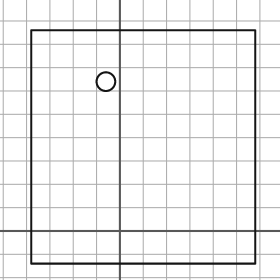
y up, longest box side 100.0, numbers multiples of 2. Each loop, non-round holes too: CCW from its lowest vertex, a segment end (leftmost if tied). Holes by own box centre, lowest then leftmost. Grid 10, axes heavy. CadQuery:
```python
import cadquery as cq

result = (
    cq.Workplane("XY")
    .moveTo(-38.0, -14.0)
    .lineTo(58.0, -14.0)
    .lineTo(58.0, 86.0)
    .lineTo(-38.0, 86.0)
    .close()
    .moveTo(-6.0, 64.0)
    .circle(4.0)
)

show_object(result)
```